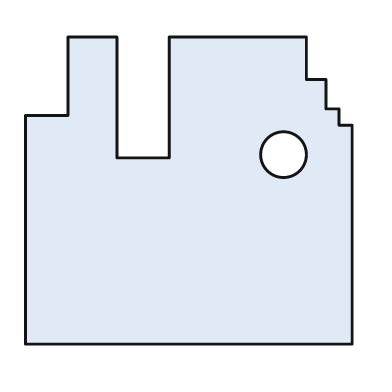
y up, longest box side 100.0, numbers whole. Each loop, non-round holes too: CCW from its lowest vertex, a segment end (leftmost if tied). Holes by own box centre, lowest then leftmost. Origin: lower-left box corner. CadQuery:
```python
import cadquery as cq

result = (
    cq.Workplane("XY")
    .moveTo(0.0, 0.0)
    .lineTo(100.0, 0.0)
    .lineTo(100.0, 67.0)
    .lineTo(96.0, 67.0)
    .lineTo(96.0, 72.0)
    .lineTo(92.0, 72.0)
    .lineTo(92.0, 81.0)
    .lineTo(86.0, 81.0)
    .lineTo(86.0, 94.0)
    .lineTo(44.0, 94.0)
    .lineTo(44.0, 57.0)
    .lineTo(28.0, 57.0)
    .lineTo(28.0, 94.0)
    .lineTo(13.0, 94.0)
    .lineTo(13.0, 70.0)
    .lineTo(0.0, 70.0)
    .close()
    .moveTo(79.0, 58.0)
    .circle(7.0)
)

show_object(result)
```